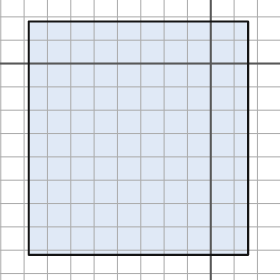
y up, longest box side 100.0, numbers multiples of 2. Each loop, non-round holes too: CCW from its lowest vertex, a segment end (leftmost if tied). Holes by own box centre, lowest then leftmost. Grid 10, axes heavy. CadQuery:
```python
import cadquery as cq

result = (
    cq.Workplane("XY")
    .moveTo(-78.0, -82.0)
    .lineTo(16.0, -82.0)
    .lineTo(16.0, 18.0)
    .lineTo(-78.0, 18.0)
    .close()
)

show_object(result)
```